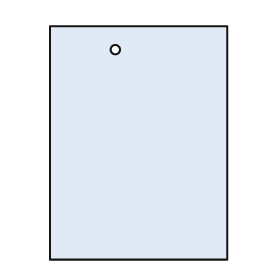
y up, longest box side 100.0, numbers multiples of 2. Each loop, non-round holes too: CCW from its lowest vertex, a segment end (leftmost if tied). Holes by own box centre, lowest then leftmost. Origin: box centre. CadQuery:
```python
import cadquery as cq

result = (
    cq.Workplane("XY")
    .moveTo(-38.0, -50.0)
    .lineTo(38.0, -50.0)
    .lineTo(38.0, 50.0)
    .lineTo(-38.0, 50.0)
    .close()
    .moveTo(-10.0, 40.0)
    .circle(2.0)
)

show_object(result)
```